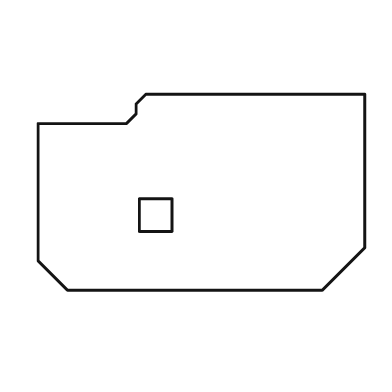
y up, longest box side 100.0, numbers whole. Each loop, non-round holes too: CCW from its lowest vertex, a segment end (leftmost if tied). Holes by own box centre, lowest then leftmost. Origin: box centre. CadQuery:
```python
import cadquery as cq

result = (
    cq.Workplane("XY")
    .moveTo(-41.0, -30.0)
    .lineTo(37.0, -30.0)
    .lineTo(50.0, -17.0)
    .lineTo(50.0, 30.0)
    .lineTo(-17.0, 30.0)
    .lineTo(-20.0, 27.0)
    .lineTo(-20.0, 24.0)
    .lineTo(-23.0, 21.0)
    .lineTo(-50.0, 21.0)
    .lineTo(-50.0, -21.0)
    .close()
    .moveTo(-19.0, -12.0)
    .lineTo(-9.0, -12.0)
    .lineTo(-9.0, -2.0)
    .lineTo(-19.0, -2.0)
    .close()
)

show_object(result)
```